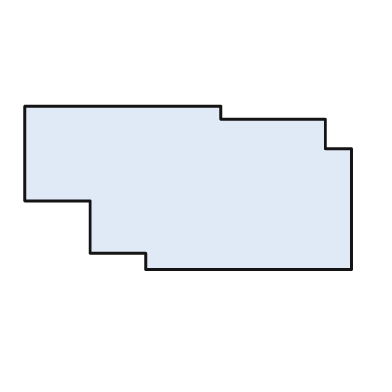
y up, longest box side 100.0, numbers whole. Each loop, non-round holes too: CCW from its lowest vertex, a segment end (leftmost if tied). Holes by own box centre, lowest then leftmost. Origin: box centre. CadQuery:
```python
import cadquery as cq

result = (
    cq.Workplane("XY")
    .moveTo(-13.0, -25.0)
    .lineTo(50.0, -25.0)
    .lineTo(50.0, 12.0)
    .lineTo(42.0, 12.0)
    .lineTo(42.0, 21.0)
    .lineTo(10.0, 21.0)
    .lineTo(10.0, 25.0)
    .lineTo(-50.0, 25.0)
    .lineTo(-50.0, -4.0)
    .lineTo(-30.0, -4.0)
    .lineTo(-30.0, -20.0)
    .lineTo(-13.0, -20.0)
    .close()
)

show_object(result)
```